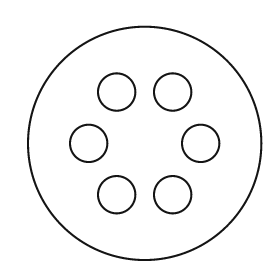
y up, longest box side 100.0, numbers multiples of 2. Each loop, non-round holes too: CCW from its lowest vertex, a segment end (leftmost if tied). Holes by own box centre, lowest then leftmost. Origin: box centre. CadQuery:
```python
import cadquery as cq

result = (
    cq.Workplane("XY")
    .moveTo(0.0, 0.0)
    .circle(50.0)
    .moveTo(-12.0, -22.0)
    .circle(8.0)
    .moveTo(12.0, -22.0)
    .circle(8.0)
    .moveTo(-24.0, 0.0)
    .circle(8.0)
    .moveTo(24.0, 0.0)
    .circle(8.0)
    .moveTo(-12.0, 22.0)
    .circle(8.0)
    .moveTo(12.0, 22.0)
    .circle(8.0)
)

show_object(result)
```